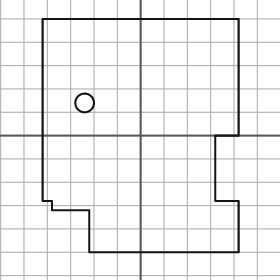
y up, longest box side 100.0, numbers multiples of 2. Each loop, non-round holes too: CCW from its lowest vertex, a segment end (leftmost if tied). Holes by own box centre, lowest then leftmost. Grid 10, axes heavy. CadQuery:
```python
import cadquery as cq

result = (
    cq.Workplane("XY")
    .moveTo(-22.0, -50.0)
    .lineTo(42.0, -50.0)
    .lineTo(42.0, -28.0)
    .lineTo(32.0, -28.0)
    .lineTo(32.0, 0.0)
    .lineTo(42.0, 0.0)
    .lineTo(42.0, 50.0)
    .lineTo(-42.0, 50.0)
    .lineTo(-42.0, -28.0)
    .lineTo(-38.0, -28.0)
    .lineTo(-38.0, -32.0)
    .lineTo(-22.0, -32.0)
    .close()
    .moveTo(-24.0, 14.0)
    .circle(4.0)
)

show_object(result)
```